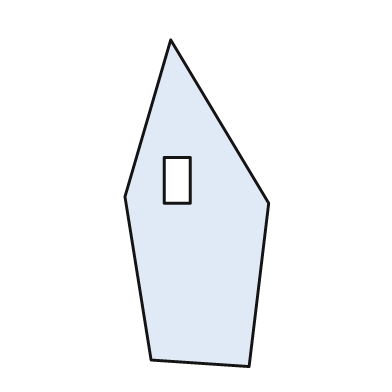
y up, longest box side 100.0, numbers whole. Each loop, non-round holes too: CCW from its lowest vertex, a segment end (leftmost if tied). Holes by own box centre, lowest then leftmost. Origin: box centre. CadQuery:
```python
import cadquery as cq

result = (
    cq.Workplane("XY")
    .moveTo(16.0, -50.0)
    .lineTo(22.0, 0.0)
    .lineTo(-8.0, 50.0)
    .lineTo(-22.0, 2.0)
    .lineTo(-14.0, -48.0)
    .close()
    .moveTo(-10.0, 0.0)
    .lineTo(-2.0, 0.0)
    .lineTo(-2.0, 14.0)
    .lineTo(-10.0, 14.0)
    .close()
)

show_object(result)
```